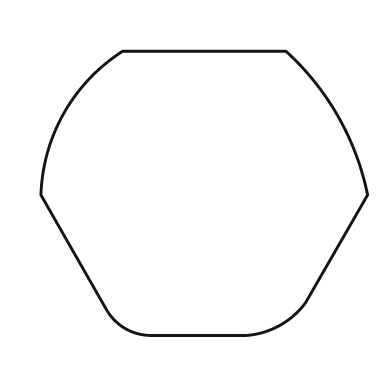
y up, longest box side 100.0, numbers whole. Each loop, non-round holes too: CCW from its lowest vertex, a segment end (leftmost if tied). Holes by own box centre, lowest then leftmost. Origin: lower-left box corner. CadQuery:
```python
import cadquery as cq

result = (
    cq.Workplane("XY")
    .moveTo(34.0, 0.0)
    .lineTo(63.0, 0.0)
    .threePointArc((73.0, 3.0), (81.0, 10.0))
    .lineTo(100.0, 43.0)
    .threePointArc((91.0, 67.0), (75.0, 87.0))
    .lineTo(25.0, 87.0)
    .threePointArc((7.0, 68.0), (0.0, 43.0))
    .lineTo(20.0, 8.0)
    .threePointArc((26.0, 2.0), (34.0, 0.0))
    .close()
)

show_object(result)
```